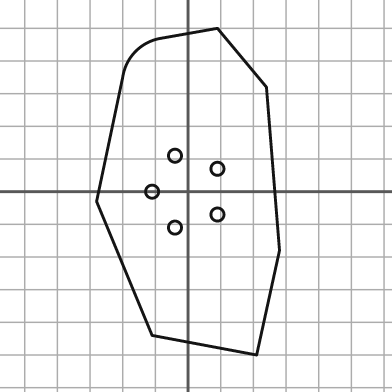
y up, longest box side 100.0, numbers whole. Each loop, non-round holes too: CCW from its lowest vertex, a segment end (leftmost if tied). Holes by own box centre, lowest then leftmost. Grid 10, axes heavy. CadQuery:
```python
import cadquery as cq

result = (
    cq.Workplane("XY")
    .moveTo(21.0, -50.0)
    .lineTo(28.0, -18.0)
    .lineTo(24.0, 32.0)
    .lineTo(9.0, 50.0)
    .lineTo(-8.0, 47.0)
    .threePointArc((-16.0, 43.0), (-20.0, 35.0))
    .lineTo(-28.0, -3.0)
    .lineTo(-11.0, -44.0)
    .close()
    .moveTo(-4.0, -11.0)
    .circle(2.0)
    .moveTo(9.0, -7.0)
    .circle(2.0)
    .moveTo(-11.0, 0.0)
    .circle(2.0)
    .moveTo(9.0, 7.0)
    .circle(2.0)
    .moveTo(-4.0, 11.0)
    .circle(2.0)
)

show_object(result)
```